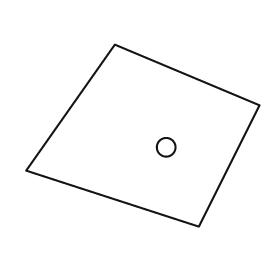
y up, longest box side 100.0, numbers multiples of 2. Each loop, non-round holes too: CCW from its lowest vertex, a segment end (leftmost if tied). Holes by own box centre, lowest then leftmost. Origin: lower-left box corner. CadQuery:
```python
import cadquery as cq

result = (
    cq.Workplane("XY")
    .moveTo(74.0, 0.0)
    .lineTo(100.0, 52.0)
    .lineTo(38.0, 78.0)
    .lineTo(0.0, 24.0)
    .close()
    .moveTo(60.0, 34.0)
    .circle(4.0)
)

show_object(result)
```